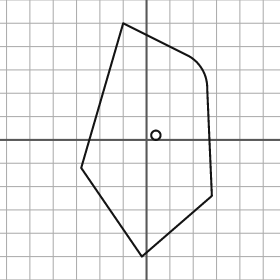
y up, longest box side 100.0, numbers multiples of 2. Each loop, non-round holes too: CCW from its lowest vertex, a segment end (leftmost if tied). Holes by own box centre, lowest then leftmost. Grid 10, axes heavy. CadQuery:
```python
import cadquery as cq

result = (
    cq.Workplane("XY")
    .moveTo(-2.0, -50.0)
    .lineTo(28.0, -24.0)
    .lineTo(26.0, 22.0)
    .threePointArc((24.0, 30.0), (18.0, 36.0))
    .lineTo(-10.0, 50.0)
    .lineTo(-28.0, -12.0)
    .close()
    .moveTo(4.0, 2.0)
    .circle(2.0)
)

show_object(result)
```